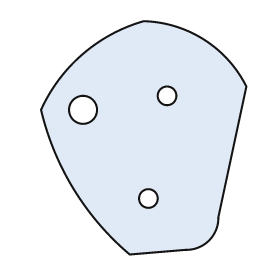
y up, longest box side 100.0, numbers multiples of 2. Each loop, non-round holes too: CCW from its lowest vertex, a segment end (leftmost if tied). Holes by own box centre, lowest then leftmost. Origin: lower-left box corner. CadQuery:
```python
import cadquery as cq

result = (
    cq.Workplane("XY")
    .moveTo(38.0, 0.0)
    .lineTo(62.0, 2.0)
    .threePointArc((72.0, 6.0), (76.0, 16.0))
    .lineTo(88.0, 72.0)
    .threePointArc((70.0, 92.0), (44.0, 100.0))
    .threePointArc((18.0, 86.0), (0.0, 62.0))
    .threePointArc((14.0, 28.0), (38.0, 0.0))
    .close()
    .moveTo(46.0, 24.0)
    .circle(4.0)
    .moveTo(18.0, 62.0)
    .circle(6.0)
    .moveTo(54.0, 68.0)
    .circle(4.0)
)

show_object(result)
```